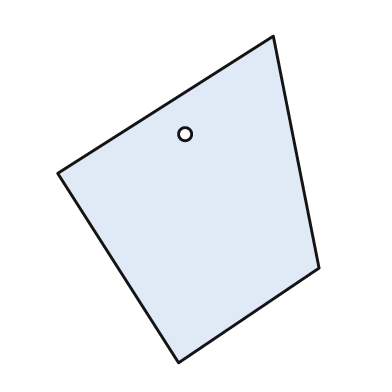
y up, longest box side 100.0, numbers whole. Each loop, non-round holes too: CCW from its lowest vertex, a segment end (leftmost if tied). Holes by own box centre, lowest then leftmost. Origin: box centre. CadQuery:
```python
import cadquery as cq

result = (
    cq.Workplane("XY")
    .moveTo(-3.0, -50.0)
    .lineTo(40.0, -21.0)
    .lineTo(26.0, 50.0)
    .lineTo(-40.0, 8.0)
    .close()
    .moveTo(-1.0, 20.0)
    .circle(2.0)
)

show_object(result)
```